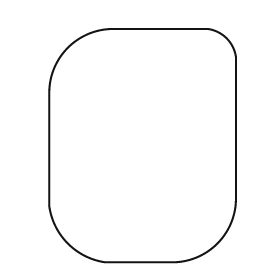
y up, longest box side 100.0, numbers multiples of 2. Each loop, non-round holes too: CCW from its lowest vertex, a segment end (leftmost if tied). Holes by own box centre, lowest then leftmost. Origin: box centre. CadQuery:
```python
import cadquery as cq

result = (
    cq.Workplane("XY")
    .moveTo(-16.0, -50.0)
    .lineTo(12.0, -50.0)
    .threePointArc((32.0, -42.0), (40.0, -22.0))
    .lineTo(40.0, 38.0)
    .threePointArc((36.0, 46.0), (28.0, 50.0))
    .lineTo(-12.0, 50.0)
    .threePointArc((-32.0, 42.0), (-40.0, 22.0))
    .lineTo(-40.0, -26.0)
    .threePointArc((-32.0, -42.0), (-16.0, -50.0))
    .close()
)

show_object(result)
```